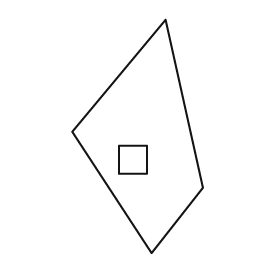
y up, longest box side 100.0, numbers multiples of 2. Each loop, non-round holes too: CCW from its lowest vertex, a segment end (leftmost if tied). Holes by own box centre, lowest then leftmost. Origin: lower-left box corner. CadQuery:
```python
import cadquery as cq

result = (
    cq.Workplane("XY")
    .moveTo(34.0, 0.0)
    .lineTo(56.0, 28.0)
    .lineTo(40.0, 100.0)
    .lineTo(0.0, 52.0)
    .close()
    .moveTo(20.0, 34.0)
    .lineTo(32.0, 34.0)
    .lineTo(32.0, 46.0)
    .lineTo(20.0, 46.0)
    .close()
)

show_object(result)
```